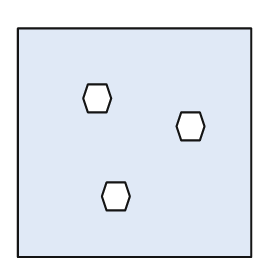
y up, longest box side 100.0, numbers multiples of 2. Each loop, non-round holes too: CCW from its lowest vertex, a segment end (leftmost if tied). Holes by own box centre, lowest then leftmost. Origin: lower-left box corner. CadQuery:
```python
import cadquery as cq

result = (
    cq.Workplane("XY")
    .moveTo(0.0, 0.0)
    .lineTo(100.0, 0.0)
    .lineTo(100.0, 98.0)
    .lineTo(0.0, 98.0)
    .close()
    .moveTo(38.0, 20.0)
    .lineTo(46.0, 20.0)
    .lineTo(48.0, 26.0)
    .lineTo(46.0, 32.0)
    .lineTo(38.0, 32.0)
    .lineTo(36.0, 26.0)
    .close()
    .moveTo(70.0, 50.0)
    .lineTo(78.0, 50.0)
    .lineTo(80.0, 56.0)
    .lineTo(78.0, 62.0)
    .lineTo(70.0, 62.0)
    .lineTo(68.0, 56.0)
    .close()
    .moveTo(30.0, 62.0)
    .lineTo(38.0, 62.0)
    .lineTo(40.0, 68.0)
    .lineTo(38.0, 74.0)
    .lineTo(30.0, 74.0)
    .lineTo(28.0, 68.0)
    .close()
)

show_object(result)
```